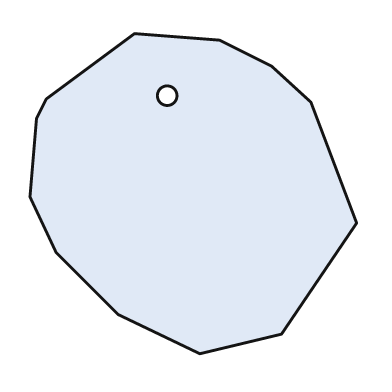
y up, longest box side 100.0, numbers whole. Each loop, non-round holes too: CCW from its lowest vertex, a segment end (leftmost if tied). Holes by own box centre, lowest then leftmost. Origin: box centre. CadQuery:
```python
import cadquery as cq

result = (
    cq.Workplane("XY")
    .moveTo(2.0, -49.0)
    .lineTo(27.0, -43.0)
    .lineTo(50.0, -9.0)
    .lineTo(36.0, 28.0)
    .lineTo(24.0, 39.0)
    .lineTo(8.0, 47.0)
    .lineTo(-18.0, 49.0)
    .lineTo(-45.0, 29.0)
    .lineTo(-48.0, 23.0)
    .lineTo(-50.0, -1.0)
    .lineTo(-42.0, -18.0)
    .lineTo(-23.0, -37.0)
    .close()
    .moveTo(-8.0, 30.0)
    .circle(3.0)
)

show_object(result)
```